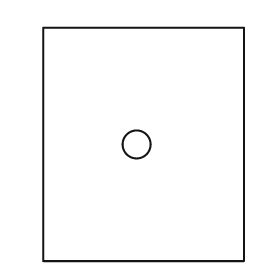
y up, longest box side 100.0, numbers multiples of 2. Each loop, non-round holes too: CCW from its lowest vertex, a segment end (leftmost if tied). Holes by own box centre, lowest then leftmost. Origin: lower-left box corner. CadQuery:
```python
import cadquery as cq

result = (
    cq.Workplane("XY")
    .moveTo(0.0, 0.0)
    .lineTo(86.0, 0.0)
    .lineTo(86.0, 100.0)
    .lineTo(0.0, 100.0)
    .close()
    .moveTo(40.0, 50.0)
    .circle(6.0)
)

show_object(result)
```